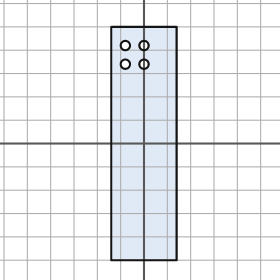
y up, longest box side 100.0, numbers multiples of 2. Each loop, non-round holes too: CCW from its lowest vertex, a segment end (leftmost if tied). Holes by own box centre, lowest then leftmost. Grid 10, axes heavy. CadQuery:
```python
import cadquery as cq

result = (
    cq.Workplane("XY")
    .moveTo(-14.0, -50.0)
    .lineTo(14.0, -50.0)
    .lineTo(14.0, 50.0)
    .lineTo(-14.0, 50.0)
    .close()
    .moveTo(-8.0, 34.0)
    .circle(2.0)
    .moveTo(0.0, 34.0)
    .circle(2.0)
    .moveTo(-8.0, 42.0)
    .circle(2.0)
    .moveTo(0.0, 42.0)
    .circle(2.0)
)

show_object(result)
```